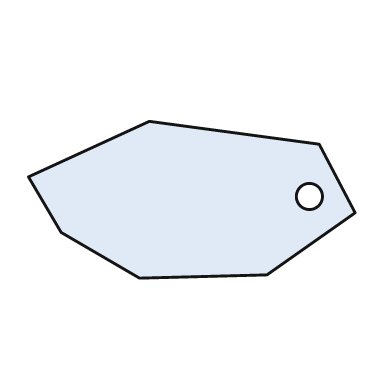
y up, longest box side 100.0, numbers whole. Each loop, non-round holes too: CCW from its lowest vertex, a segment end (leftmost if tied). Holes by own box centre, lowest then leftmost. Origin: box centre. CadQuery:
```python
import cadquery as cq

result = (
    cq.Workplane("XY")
    .moveTo(-16.0, -24.0)
    .lineTo(23.0, -23.0)
    .lineTo(50.0, -4.0)
    .lineTo(39.0, 17.0)
    .lineTo(-13.0, 24.0)
    .lineTo(-50.0, 7.0)
    .lineTo(-40.0, -10.0)
    .close()
    .moveTo(36.0, 1.0)
    .circle(4.0)
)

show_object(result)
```